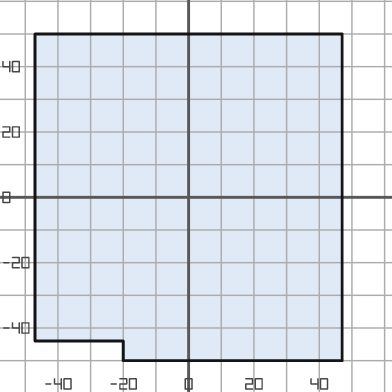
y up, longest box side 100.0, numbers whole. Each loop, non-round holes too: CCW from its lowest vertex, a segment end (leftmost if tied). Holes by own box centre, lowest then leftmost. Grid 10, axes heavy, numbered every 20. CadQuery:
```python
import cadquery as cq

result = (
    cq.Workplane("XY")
    .moveTo(-20.0, -50.0)
    .lineTo(47.0, -50.0)
    .lineTo(47.0, 50.0)
    .lineTo(-47.0, 50.0)
    .lineTo(-47.0, -44.0)
    .lineTo(-20.0, -44.0)
    .close()
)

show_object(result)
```